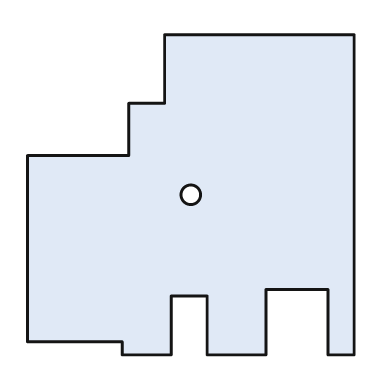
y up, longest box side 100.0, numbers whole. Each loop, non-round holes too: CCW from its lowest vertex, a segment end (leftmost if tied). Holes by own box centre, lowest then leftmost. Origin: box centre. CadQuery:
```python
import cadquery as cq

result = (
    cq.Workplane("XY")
    .moveTo(-21.0, -49.0)
    .lineTo(-6.0, -49.0)
    .lineTo(-6.0, -31.0)
    .lineTo(5.0, -31.0)
    .lineTo(5.0, -49.0)
    .lineTo(23.0, -49.0)
    .lineTo(23.0, -29.0)
    .lineTo(42.0, -29.0)
    .lineTo(42.0, -49.0)
    .lineTo(50.0, -49.0)
    .lineTo(50.0, 49.0)
    .lineTo(-8.0, 49.0)
    .lineTo(-8.0, 28.0)
    .lineTo(-19.0, 28.0)
    .lineTo(-19.0, 12.0)
    .lineTo(-50.0, 12.0)
    .lineTo(-50.0, -45.0)
    .lineTo(-21.0, -45.0)
    .close()
    .moveTo(0.0, 0.0)
    .circle(3.0)
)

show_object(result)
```